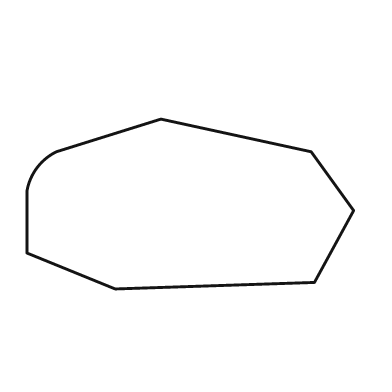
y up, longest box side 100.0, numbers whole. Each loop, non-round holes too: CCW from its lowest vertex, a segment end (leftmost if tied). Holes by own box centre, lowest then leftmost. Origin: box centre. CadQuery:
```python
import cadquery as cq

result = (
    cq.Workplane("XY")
    .moveTo(-23.0, -26.0)
    .lineTo(38.0, -24.0)
    .lineTo(50.0, -2.0)
    .lineTo(37.0, 16.0)
    .lineTo(-9.0, 26.0)
    .lineTo(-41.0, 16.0)
    .threePointArc((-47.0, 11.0), (-50.0, 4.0))
    .lineTo(-50.0, -15.0)
    .close()
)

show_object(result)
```